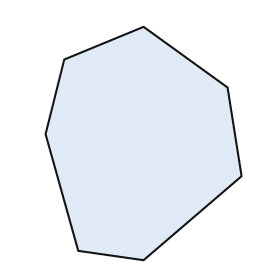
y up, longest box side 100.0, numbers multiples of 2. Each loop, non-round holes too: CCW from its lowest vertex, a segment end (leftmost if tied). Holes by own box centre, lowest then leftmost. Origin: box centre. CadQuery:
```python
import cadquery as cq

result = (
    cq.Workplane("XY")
    .moveTo(0.0, -50.0)
    .lineTo(42.0, -14.0)
    .lineTo(36.0, 24.0)
    .lineTo(0.0, 50.0)
    .lineTo(-34.0, 36.0)
    .lineTo(-42.0, 4.0)
    .lineTo(-28.0, -46.0)
    .close()
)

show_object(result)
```